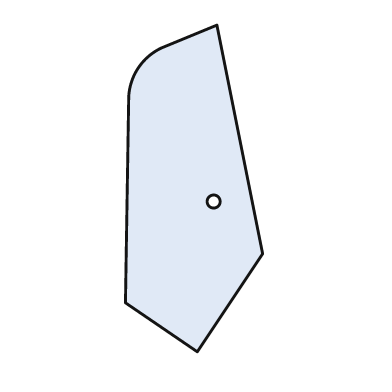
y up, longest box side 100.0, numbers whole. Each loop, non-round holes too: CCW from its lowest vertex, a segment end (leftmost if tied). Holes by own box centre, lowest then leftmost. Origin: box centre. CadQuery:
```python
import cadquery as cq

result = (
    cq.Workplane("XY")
    .moveTo(1.0, -50.0)
    .lineTo(21.0, -20.0)
    .lineTo(7.0, 50.0)
    .lineTo(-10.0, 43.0)
    .threePointArc((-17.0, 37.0), (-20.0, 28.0))
    .lineTo(-21.0, -35.0)
    .close()
    .moveTo(6.0, -4.0)
    .circle(2.0)
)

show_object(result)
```